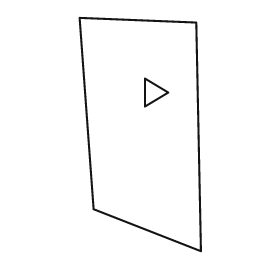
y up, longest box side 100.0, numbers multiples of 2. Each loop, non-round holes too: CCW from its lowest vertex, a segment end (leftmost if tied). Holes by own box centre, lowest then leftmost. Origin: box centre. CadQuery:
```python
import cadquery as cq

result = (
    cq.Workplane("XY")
    .moveTo(26.0, -50.0)
    .lineTo(24.0, 48.0)
    .lineTo(-26.0, 50.0)
    .lineTo(-20.0, -32.0)
    .close()
    .moveTo(2.0, 12.0)
    .lineTo(12.0, 18.0)
    .lineTo(2.0, 24.0)
    .close()
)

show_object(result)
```